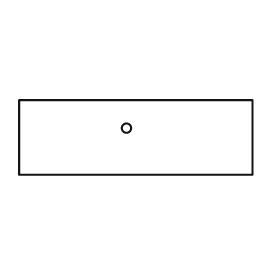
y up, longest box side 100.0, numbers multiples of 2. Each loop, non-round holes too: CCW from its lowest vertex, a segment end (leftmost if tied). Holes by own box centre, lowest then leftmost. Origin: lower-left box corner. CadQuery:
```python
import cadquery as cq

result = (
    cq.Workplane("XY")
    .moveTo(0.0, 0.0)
    .lineTo(100.0, 0.0)
    .lineTo(100.0, 32.0)
    .lineTo(0.0, 32.0)
    .close()
    .moveTo(46.0, 20.0)
    .circle(2.0)
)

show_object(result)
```